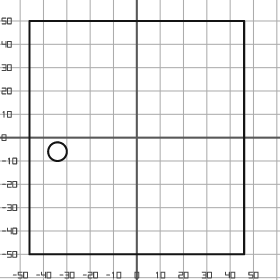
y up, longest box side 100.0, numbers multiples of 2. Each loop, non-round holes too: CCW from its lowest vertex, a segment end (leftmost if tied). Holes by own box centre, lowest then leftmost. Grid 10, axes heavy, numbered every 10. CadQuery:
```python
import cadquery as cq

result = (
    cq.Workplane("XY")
    .moveTo(-46.0, -50.0)
    .lineTo(46.0, -50.0)
    .lineTo(46.0, 50.0)
    .lineTo(-46.0, 50.0)
    .close()
    .moveTo(-34.0, -6.0)
    .circle(4.0)
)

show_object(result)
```